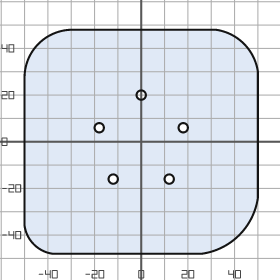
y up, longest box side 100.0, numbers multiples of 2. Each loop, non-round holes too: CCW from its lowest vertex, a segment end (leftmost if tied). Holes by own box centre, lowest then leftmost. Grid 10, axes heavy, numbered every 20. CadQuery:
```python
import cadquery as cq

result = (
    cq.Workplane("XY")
    .moveTo(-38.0, -48.0)
    .lineTo(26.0, -48.0)
    .threePointArc((42.0, -40.0), (50.0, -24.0))
    .lineTo(50.0, 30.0)
    .threePointArc((44.0, 42.0), (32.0, 48.0))
    .lineTo(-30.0, 48.0)
    .threePointArc((-44.0, 42.0), (-50.0, 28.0))
    .lineTo(-50.0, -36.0)
    .threePointArc((-46.0, -44.0), (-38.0, -48.0))
    .close()
    .moveTo(-12.0, -16.0)
    .circle(2.0)
    .moveTo(12.0, -16.0)
    .circle(2.0)
    .moveTo(-18.0, 6.0)
    .circle(2.0)
    .moveTo(18.0, 6.0)
    .circle(2.0)
    .moveTo(0.0, 20.0)
    .circle(2.0)
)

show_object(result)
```